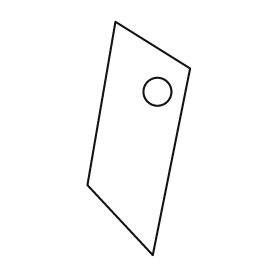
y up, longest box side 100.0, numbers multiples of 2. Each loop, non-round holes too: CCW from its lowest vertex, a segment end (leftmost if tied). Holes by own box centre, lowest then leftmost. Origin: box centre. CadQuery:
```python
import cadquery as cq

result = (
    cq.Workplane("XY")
    .moveTo(6.0, -50.0)
    .lineTo(22.0, 30.0)
    .lineTo(-10.0, 50.0)
    .lineTo(-22.0, -20.0)
    .close()
    .moveTo(8.0, 20.0)
    .circle(6.0)
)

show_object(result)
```